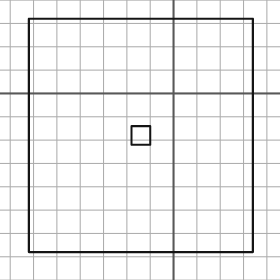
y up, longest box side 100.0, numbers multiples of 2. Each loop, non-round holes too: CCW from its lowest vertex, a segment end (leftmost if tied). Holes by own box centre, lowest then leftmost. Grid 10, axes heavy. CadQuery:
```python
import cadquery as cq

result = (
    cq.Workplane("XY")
    .moveTo(-62.0, -68.0)
    .lineTo(34.0, -68.0)
    .lineTo(34.0, 32.0)
    .lineTo(-62.0, 32.0)
    .close()
    .moveTo(-18.0, -22.0)
    .lineTo(-10.0, -22.0)
    .lineTo(-10.0, -14.0)
    .lineTo(-18.0, -14.0)
    .close()
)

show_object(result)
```